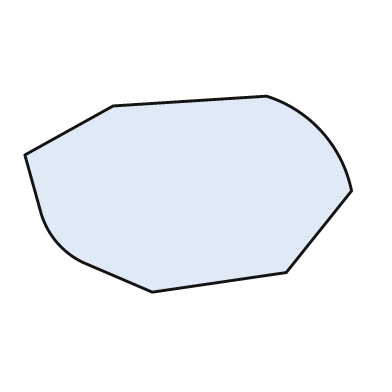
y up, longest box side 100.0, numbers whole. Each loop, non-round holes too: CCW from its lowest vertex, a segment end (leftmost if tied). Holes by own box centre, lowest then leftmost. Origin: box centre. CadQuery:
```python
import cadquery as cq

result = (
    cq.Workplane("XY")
    .moveTo(-11.0, -30.0)
    .lineTo(30.0, -24.0)
    .lineTo(50.0, 1.0)
    .threePointArc((41.0, 19.0), (24.0, 30.0))
    .lineTo(-23.0, 27.0)
    .lineTo(-50.0, 12.0)
    .lineTo(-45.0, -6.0)
    .threePointArc((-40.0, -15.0), (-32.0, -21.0))
    .close()
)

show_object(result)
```